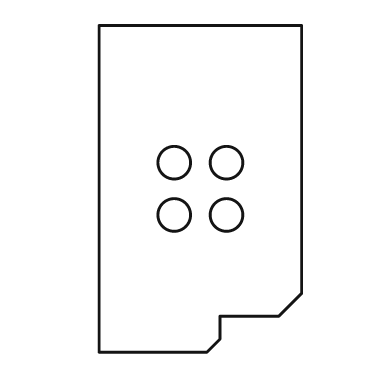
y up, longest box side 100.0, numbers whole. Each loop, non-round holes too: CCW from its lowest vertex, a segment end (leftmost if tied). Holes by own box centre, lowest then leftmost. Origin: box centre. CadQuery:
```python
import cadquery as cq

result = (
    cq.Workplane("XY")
    .moveTo(-31.0, -50.0)
    .lineTo(2.0, -50.0)
    .lineTo(6.0, -46.0)
    .lineTo(6.0, -39.0)
    .lineTo(24.0, -39.0)
    .lineTo(31.0, -32.0)
    .lineTo(31.0, 50.0)
    .lineTo(-31.0, 50.0)
    .close()
    .moveTo(-8.0, -8.0)
    .circle(5.0)
    .moveTo(8.0, -8.0)
    .circle(5.0)
    .moveTo(-8.0, 8.0)
    .circle(5.0)
    .moveTo(8.0, 8.0)
    .circle(5.0)
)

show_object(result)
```